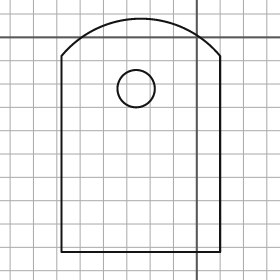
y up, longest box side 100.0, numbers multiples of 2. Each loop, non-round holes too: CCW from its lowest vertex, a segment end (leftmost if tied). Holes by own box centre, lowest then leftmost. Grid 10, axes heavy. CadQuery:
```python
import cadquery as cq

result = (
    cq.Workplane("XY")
    .moveTo(-58.0, -92.0)
    .lineTo(10.0, -92.0)
    .lineTo(10.0, -8.0)
    .threePointArc((-24.0, 8.0), (-58.0, -8.0))
    .close()
    .moveTo(-26.0, -22.0)
    .circle(8.0)
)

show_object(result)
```